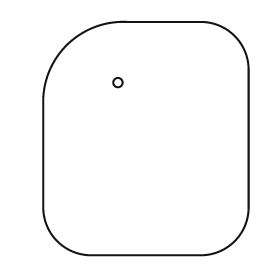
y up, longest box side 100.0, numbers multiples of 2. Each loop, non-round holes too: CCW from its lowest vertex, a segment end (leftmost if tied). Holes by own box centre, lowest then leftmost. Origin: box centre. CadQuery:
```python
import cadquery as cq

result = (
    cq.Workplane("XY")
    .moveTo(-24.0, -50.0)
    .lineTo(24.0, -50.0)
    .threePointArc((38.0, -44.0), (44.0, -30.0))
    .lineTo(44.0, 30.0)
    .threePointArc((38.0, 44.0), (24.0, 50.0))
    .lineTo(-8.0, 50.0)
    .threePointArc((-34.0, 40.0), (-44.0, 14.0))
    .lineTo(-44.0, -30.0)
    .threePointArc((-38.0, -44.0), (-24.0, -50.0))
    .close()
    .moveTo(-12.0, 24.0)
    .circle(2.0)
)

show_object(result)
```